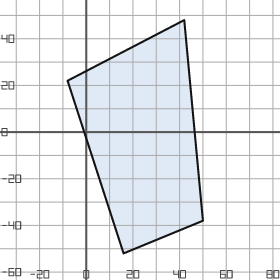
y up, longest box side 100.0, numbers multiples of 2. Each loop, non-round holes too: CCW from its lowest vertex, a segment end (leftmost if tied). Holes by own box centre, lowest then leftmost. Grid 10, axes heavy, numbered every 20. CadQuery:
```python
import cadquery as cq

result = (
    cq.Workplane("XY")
    .moveTo(16.0, -52.0)
    .lineTo(50.0, -38.0)
    .lineTo(42.0, 48.0)
    .lineTo(-8.0, 22.0)
    .close()
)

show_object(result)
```